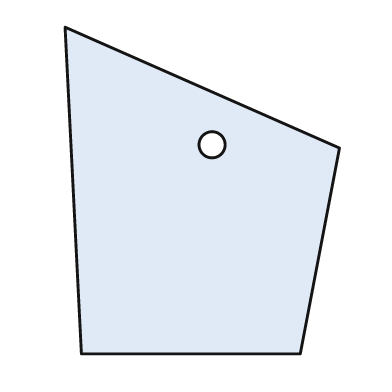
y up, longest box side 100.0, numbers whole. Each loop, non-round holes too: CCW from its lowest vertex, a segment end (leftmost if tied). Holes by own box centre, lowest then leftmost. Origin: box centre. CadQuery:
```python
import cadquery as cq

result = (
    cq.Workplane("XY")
    .moveTo(-37.0, -50.0)
    .lineTo(30.0, -50.0)
    .lineTo(42.0, 13.0)
    .lineTo(-42.0, 50.0)
    .close()
    .moveTo(3.0, 14.0)
    .circle(4.0)
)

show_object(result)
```